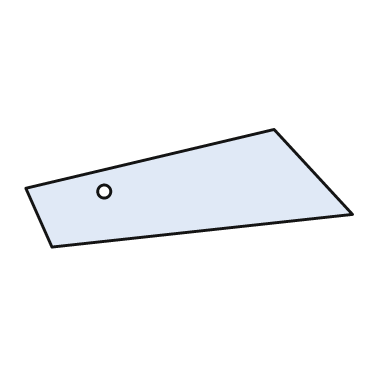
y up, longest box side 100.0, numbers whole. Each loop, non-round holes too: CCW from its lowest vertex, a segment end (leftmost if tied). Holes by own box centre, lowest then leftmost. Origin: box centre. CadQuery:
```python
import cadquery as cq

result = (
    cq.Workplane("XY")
    .moveTo(-42.0, -18.0)
    .lineTo(50.0, -8.0)
    .lineTo(26.0, 18.0)
    .lineTo(-50.0, 0.0)
    .close()
    .moveTo(-26.0, -1.0)
    .circle(2.0)
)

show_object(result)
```